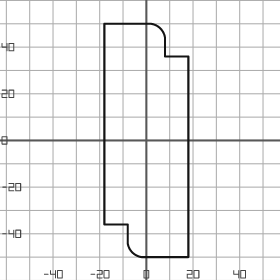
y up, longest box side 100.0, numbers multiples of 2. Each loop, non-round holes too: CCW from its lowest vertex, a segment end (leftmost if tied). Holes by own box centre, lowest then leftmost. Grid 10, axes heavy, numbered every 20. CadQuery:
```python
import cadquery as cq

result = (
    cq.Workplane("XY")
    .moveTo(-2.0, -50.0)
    .lineTo(18.0, -50.0)
    .lineTo(18.0, 36.0)
    .lineTo(8.0, 36.0)
    .lineTo(8.0, 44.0)
    .threePointArc((6.0, 48.0), (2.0, 50.0))
    .lineTo(-18.0, 50.0)
    .lineTo(-18.0, -36.0)
    .lineTo(-8.0, -36.0)
    .lineTo(-8.0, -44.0)
    .threePointArc((-6.0, -48.0), (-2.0, -50.0))
    .close()
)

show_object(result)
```